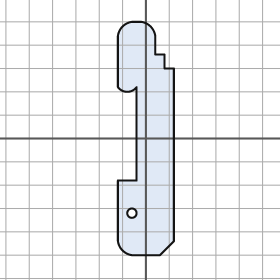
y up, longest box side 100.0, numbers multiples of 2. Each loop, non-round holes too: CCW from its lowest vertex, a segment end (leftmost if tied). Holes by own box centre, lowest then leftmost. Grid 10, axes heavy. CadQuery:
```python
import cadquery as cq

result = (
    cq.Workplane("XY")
    .moveTo(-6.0, -50.0)
    .lineTo(6.0, -50.0)
    .lineTo(12.0, -44.0)
    .lineTo(12.0, 30.0)
    .lineTo(8.0, 30.0)
    .lineTo(8.0, 36.0)
    .lineTo(4.0, 36.0)
    .lineTo(4.0, 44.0)
    .threePointArc((2.0, 48.0), (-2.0, 50.0))
    .lineTo(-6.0, 50.0)
    .threePointArc((-10.0, 48.0), (-12.0, 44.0))
    .lineTo(-12.0, 22.0)
    .threePointArc((-8.0, 20.0), (-4.0, 22.0))
    .lineTo(-4.0, -18.0)
    .lineTo(-12.0, -18.0)
    .lineTo(-12.0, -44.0)
    .threePointArc((-10.0, -48.0), (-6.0, -50.0))
    .close()
    .moveTo(-6.0, -32.0)
    .circle(2.0)
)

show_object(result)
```